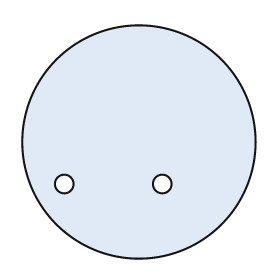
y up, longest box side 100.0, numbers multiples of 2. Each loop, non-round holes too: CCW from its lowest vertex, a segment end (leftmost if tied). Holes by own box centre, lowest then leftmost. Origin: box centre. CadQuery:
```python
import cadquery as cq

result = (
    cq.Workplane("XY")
    .moveTo(0.0, 0.0)
    .circle(50.0)
    .moveTo(-32.0, -18.0)
    .circle(4.0)
    .moveTo(10.0, -18.0)
    .circle(4.0)
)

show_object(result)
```